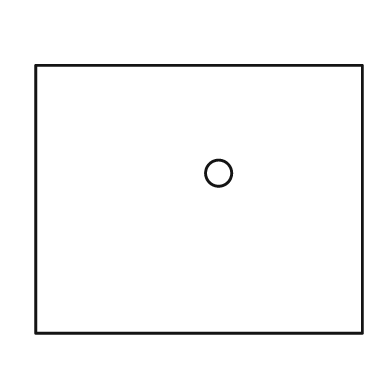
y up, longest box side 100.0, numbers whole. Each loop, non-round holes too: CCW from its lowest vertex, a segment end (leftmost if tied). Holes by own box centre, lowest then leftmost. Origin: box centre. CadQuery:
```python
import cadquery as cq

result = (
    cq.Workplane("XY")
    .moveTo(-50.0, -41.0)
    .lineTo(50.0, -41.0)
    .lineTo(50.0, 41.0)
    .lineTo(-50.0, 41.0)
    .close()
    .moveTo(6.0, 8.0)
    .circle(4.0)
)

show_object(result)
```